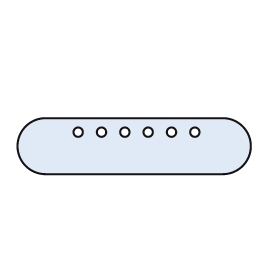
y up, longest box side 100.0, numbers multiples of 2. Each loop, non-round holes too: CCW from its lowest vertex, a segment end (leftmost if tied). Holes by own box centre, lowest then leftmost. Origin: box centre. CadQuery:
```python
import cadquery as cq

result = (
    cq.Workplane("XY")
    .moveTo(-38.0, -12.0)
    .lineTo(38.0, -12.0)
    .threePointArc((50.0, 0.0), (38.0, 12.0))
    .lineTo(-38.0, 12.0)
    .threePointArc((-50.0, 0.0), (-38.0, -12.0))
    .close()
    .moveTo(-24.0, 6.0)
    .circle(2.0)
    .moveTo(-14.0, 6.0)
    .circle(2.0)
    .moveTo(-4.0, 6.0)
    .circle(2.0)
    .moveTo(6.0, 6.0)
    .circle(2.0)
    .moveTo(16.0, 6.0)
    .circle(2.0)
    .moveTo(26.0, 6.0)
    .circle(2.0)
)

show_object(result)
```